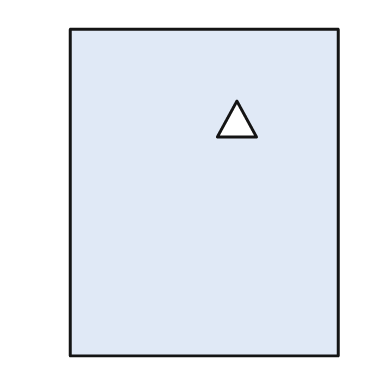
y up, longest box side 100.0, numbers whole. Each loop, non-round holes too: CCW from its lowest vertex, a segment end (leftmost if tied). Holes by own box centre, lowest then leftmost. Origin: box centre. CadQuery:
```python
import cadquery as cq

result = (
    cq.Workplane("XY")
    .moveTo(-41.0, -50.0)
    .lineTo(41.0, -50.0)
    .lineTo(41.0, 50.0)
    .lineTo(-41.0, 50.0)
    .close()
    .moveTo(4.0, 17.0)
    .lineTo(16.0, 17.0)
    .lineTo(10.0, 28.0)
    .close()
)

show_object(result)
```